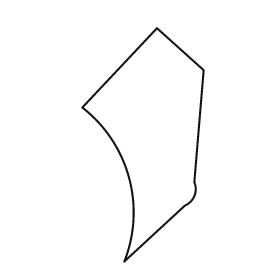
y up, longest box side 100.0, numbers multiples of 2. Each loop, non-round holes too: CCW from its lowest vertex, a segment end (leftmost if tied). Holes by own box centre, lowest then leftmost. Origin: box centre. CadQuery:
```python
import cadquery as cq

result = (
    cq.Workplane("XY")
    .moveTo(-8.0, -50.0)
    .lineTo(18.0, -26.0)
    .threePointArc((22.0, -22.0), (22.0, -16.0))
    .lineTo(26.0, 32.0)
    .lineTo(6.0, 50.0)
    .lineTo(-26.0, 16.0)
    .threePointArc((-6.0, -14.0), (-8.0, -50.0))
    .close()
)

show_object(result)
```